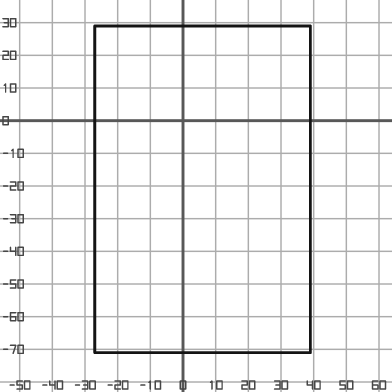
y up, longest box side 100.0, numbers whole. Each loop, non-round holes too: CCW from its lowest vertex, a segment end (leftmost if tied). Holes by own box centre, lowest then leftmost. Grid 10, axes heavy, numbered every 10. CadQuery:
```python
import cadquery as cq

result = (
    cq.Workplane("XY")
    .moveTo(-27.0, -71.0)
    .lineTo(39.0, -71.0)
    .lineTo(39.0, 29.0)
    .lineTo(-27.0, 29.0)
    .close()
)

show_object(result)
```